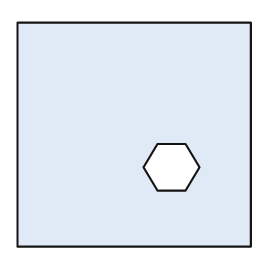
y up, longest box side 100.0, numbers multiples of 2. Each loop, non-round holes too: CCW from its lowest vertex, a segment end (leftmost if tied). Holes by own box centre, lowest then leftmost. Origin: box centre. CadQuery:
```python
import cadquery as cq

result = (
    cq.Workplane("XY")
    .moveTo(-50.0, -48.0)
    .lineTo(50.0, -48.0)
    .lineTo(50.0, 48.0)
    .lineTo(-50.0, 48.0)
    .close()
    .moveTo(10.0, -24.0)
    .lineTo(22.0, -24.0)
    .lineTo(28.0, -14.0)
    .lineTo(22.0, -4.0)
    .lineTo(10.0, -4.0)
    .lineTo(4.0, -14.0)
    .close()
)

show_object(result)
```